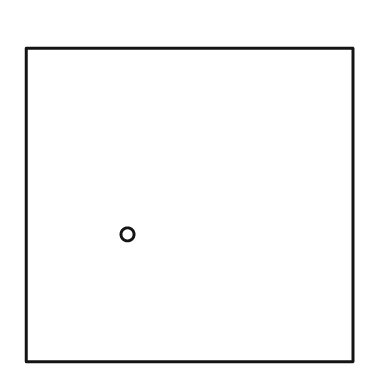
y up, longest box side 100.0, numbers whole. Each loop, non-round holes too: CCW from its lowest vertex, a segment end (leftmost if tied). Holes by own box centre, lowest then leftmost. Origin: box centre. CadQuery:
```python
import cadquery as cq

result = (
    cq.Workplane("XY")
    .moveTo(-50.0, -48.0)
    .lineTo(50.0, -48.0)
    .lineTo(50.0, 48.0)
    .lineTo(-50.0, 48.0)
    .close()
    .moveTo(-19.0, -9.0)
    .circle(2.0)
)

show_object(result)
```